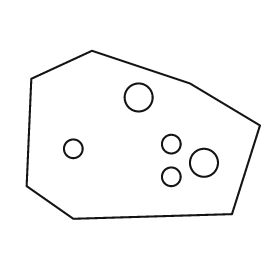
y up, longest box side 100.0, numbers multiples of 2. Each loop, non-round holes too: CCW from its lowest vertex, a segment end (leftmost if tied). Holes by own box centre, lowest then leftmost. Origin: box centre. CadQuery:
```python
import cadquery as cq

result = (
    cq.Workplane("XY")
    .moveTo(-30.0, -36.0)
    .lineTo(38.0, -34.0)
    .lineTo(50.0, 4.0)
    .lineTo(20.0, 22.0)
    .lineTo(-22.0, 36.0)
    .lineTo(-48.0, 24.0)
    .lineTo(-50.0, -22.0)
    .close()
    .moveTo(12.0, -18.0)
    .circle(4.0)
    .moveTo(26.0, -12.0)
    .circle(6.0)
    .moveTo(-30.0, -6.0)
    .circle(4.0)
    .moveTo(12.0, -4.0)
    .circle(4.0)
    .moveTo(-2.0, 16.0)
    .circle(6.0)
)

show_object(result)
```